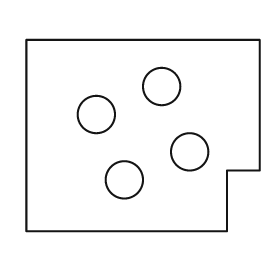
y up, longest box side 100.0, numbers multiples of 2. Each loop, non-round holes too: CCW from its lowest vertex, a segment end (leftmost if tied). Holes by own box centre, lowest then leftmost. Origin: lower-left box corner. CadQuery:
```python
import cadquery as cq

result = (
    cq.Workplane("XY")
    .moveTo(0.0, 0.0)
    .lineTo(86.0, 0.0)
    .lineTo(86.0, 26.0)
    .lineTo(100.0, 26.0)
    .lineTo(100.0, 82.0)
    .lineTo(0.0, 82.0)
    .close()
    .moveTo(42.0, 22.0)
    .circle(8.0)
    .moveTo(70.0, 34.0)
    .circle(8.0)
    .moveTo(30.0, 50.0)
    .circle(8.0)
    .moveTo(58.0, 62.0)
    .circle(8.0)
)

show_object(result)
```